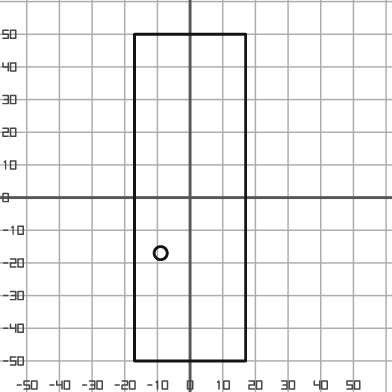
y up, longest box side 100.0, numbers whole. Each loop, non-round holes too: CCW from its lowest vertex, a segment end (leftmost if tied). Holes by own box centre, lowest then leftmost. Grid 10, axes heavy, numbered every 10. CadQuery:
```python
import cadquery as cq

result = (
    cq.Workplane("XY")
    .moveTo(-17.0, -50.0)
    .lineTo(17.0, -50.0)
    .lineTo(17.0, 50.0)
    .lineTo(-17.0, 50.0)
    .close()
    .moveTo(-9.0, -17.0)
    .circle(2.0)
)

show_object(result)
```